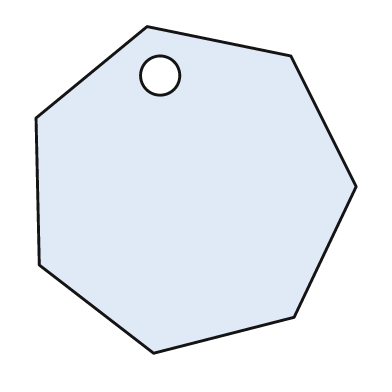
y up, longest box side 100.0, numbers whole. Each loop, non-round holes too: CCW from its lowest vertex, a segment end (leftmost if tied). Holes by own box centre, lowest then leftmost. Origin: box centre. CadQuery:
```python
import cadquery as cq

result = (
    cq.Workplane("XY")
    .moveTo(-13.0, -50.0)
    .lineTo(30.0, -39.0)
    .lineTo(49.0, 1.0)
    .lineTo(29.0, 41.0)
    .lineTo(-15.0, 50.0)
    .lineTo(-49.0, 22.0)
    .lineTo(-48.0, -23.0)
    .close()
    .moveTo(-11.0, 35.0)
    .circle(6.0)
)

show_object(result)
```